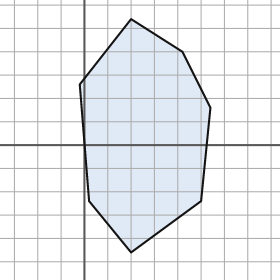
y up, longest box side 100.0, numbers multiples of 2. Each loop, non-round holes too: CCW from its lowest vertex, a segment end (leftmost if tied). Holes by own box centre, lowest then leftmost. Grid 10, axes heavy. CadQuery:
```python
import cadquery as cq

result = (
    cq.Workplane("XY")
    .moveTo(20.0, -46.0)
    .lineTo(50.0, -24.0)
    .lineTo(54.0, 16.0)
    .lineTo(42.0, 40.0)
    .lineTo(20.0, 54.0)
    .lineTo(-2.0, 26.0)
    .lineTo(2.0, -24.0)
    .close()
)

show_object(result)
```